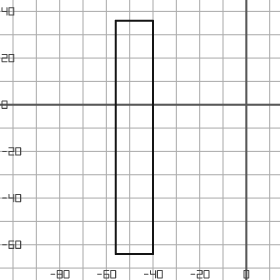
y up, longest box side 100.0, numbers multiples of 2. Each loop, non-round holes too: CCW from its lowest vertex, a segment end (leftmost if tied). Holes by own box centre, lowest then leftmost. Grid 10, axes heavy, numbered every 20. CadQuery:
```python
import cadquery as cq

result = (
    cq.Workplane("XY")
    .moveTo(-56.0, -64.0)
    .lineTo(-40.0, -64.0)
    .lineTo(-40.0, 36.0)
    .lineTo(-56.0, 36.0)
    .close()
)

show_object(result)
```